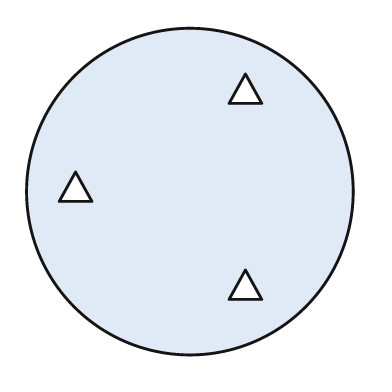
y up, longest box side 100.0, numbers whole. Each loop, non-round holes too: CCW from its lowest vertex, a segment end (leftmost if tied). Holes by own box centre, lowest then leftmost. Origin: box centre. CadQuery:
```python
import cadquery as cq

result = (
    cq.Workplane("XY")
    .moveTo(0.0, 0.0)
    .circle(50.0)
    .moveTo(12.0, -33.0)
    .lineTo(22.0, -33.0)
    .lineTo(17.0, -24.0)
    .close()
    .moveTo(-40.0, -3.0)
    .lineTo(-30.0, -3.0)
    .lineTo(-35.0, 6.0)
    .close()
    .moveTo(12.0, 27.0)
    .lineTo(22.0, 27.0)
    .lineTo(17.0, 36.0)
    .close()
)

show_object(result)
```